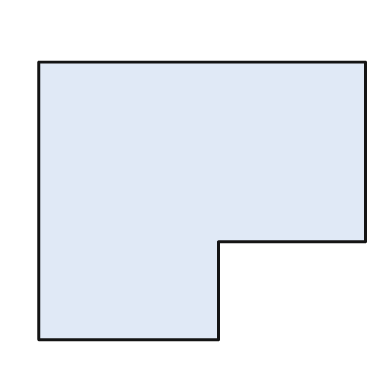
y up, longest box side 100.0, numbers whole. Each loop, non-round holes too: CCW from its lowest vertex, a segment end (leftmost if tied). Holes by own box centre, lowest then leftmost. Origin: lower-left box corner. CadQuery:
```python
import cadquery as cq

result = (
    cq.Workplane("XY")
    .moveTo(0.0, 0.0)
    .lineTo(55.0, 0.0)
    .lineTo(55.0, 30.0)
    .lineTo(100.0, 30.0)
    .lineTo(100.0, 85.0)
    .lineTo(0.0, 85.0)
    .close()
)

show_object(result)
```